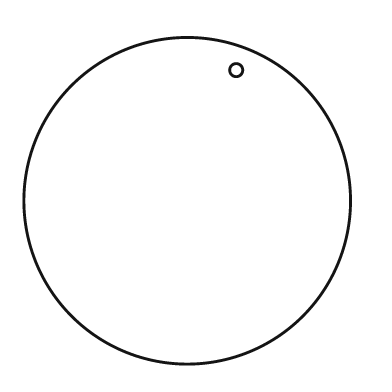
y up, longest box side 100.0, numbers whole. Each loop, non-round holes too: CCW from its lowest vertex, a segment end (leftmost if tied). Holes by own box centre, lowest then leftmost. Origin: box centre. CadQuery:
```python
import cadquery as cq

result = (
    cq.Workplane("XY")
    .moveTo(0.0, 0.0)
    .circle(50.0)
    .moveTo(15.0, 40.0)
    .circle(2.0)
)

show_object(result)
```